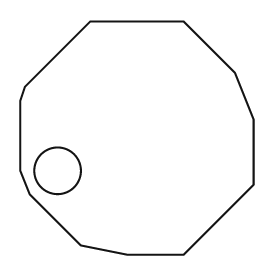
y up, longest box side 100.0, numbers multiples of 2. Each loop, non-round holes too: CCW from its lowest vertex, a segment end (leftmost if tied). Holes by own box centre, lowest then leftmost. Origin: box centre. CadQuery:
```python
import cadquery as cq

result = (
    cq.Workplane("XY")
    .moveTo(-4.0, -50.0)
    .lineTo(20.0, -50.0)
    .lineTo(50.0, -20.0)
    .lineTo(50.0, 8.0)
    .lineTo(42.0, 28.0)
    .lineTo(20.0, 50.0)
    .lineTo(-20.0, 50.0)
    .lineTo(-48.0, 22.0)
    .lineTo(-50.0, 16.0)
    .lineTo(-50.0, -14.0)
    .lineTo(-46.0, -24.0)
    .lineTo(-24.0, -46.0)
    .close()
    .moveTo(-34.0, -14.0)
    .circle(10.0)
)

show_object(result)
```